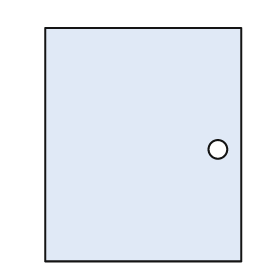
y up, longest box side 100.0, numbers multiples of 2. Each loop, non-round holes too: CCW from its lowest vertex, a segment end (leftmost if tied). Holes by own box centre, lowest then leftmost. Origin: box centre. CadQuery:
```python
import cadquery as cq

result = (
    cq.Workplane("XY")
    .moveTo(-42.0, -50.0)
    .lineTo(42.0, -50.0)
    .lineTo(42.0, 50.0)
    .lineTo(-42.0, 50.0)
    .close()
    .moveTo(32.0, -2.0)
    .circle(4.0)
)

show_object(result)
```